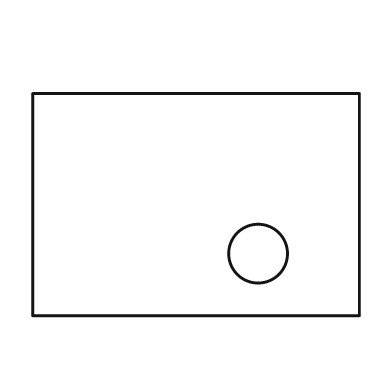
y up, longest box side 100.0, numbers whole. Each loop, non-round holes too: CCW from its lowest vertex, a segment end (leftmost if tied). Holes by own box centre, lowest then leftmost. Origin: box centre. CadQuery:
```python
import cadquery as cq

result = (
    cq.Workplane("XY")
    .moveTo(-50.0, -34.0)
    .lineTo(50.0, -34.0)
    .lineTo(50.0, 34.0)
    .lineTo(-50.0, 34.0)
    .close()
    .moveTo(19.0, -15.0)
    .circle(9.0)
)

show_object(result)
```